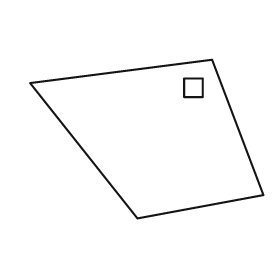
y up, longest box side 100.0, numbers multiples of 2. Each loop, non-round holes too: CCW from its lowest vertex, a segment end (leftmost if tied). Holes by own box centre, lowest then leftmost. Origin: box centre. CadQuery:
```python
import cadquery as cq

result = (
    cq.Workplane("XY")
    .moveTo(-4.0, -34.0)
    .lineTo(50.0, -24.0)
    .lineTo(28.0, 34.0)
    .lineTo(-50.0, 24.0)
    .close()
    .moveTo(16.0, 18.0)
    .lineTo(24.0, 18.0)
    .lineTo(24.0, 26.0)
    .lineTo(16.0, 26.0)
    .close()
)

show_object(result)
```